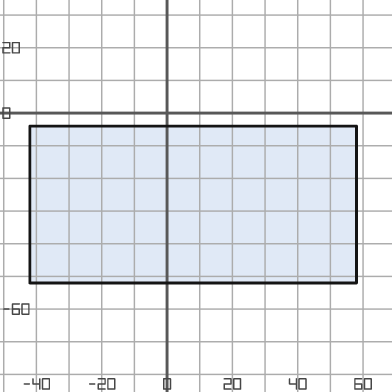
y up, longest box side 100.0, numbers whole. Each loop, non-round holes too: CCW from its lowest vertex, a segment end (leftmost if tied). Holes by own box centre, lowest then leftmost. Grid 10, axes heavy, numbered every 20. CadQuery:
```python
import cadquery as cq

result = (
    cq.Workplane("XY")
    .moveTo(-42.0, -52.0)
    .lineTo(58.0, -52.0)
    .lineTo(58.0, -4.0)
    .lineTo(-42.0, -4.0)
    .close()
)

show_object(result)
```